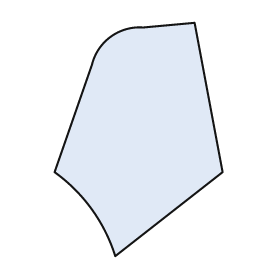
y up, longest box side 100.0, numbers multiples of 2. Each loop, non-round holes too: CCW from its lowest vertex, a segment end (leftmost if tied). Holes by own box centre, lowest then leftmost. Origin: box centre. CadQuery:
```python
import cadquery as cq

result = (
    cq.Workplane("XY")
    .moveTo(-10.0, -50.0)
    .lineTo(36.0, -14.0)
    .lineTo(24.0, 50.0)
    .lineTo(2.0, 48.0)
    .threePointArc((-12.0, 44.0), (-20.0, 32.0))
    .lineTo(-36.0, -14.0)
    .threePointArc((-20.0, -30.0), (-10.0, -50.0))
    .close()
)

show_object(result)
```